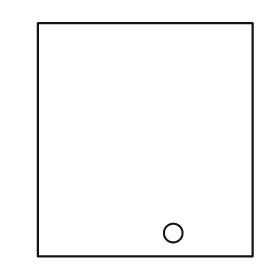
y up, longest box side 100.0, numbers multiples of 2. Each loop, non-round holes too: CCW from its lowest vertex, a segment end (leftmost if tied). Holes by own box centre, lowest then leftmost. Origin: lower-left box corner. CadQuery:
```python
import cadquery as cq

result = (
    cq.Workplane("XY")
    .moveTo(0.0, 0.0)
    .lineTo(92.0, 0.0)
    .lineTo(92.0, 100.0)
    .lineTo(0.0, 100.0)
    .close()
    .moveTo(58.0, 10.0)
    .circle(4.0)
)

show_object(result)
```